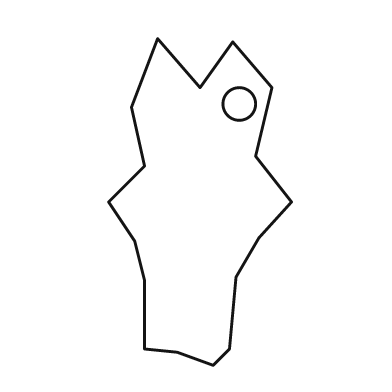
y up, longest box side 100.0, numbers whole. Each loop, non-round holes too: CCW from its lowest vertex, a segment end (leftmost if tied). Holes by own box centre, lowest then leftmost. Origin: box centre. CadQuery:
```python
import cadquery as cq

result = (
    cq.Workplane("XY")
    .moveTo(4.0, -50.0)
    .lineTo(9.0, -45.0)
    .lineTo(11.0, -23.0)
    .lineTo(18.0, -11.0)
    .lineTo(28.0, 0.0)
    .lineTo(17.0, 14.0)
    .lineTo(22.0, 35.0)
    .lineTo(10.0, 49.0)
    .lineTo(0.0, 35.0)
    .lineTo(-13.0, 50.0)
    .lineTo(-21.0, 29.0)
    .lineTo(-17.0, 11.0)
    .lineTo(-28.0, 0.0)
    .lineTo(-20.0, -12.0)
    .lineTo(-17.0, -24.0)
    .lineTo(-17.0, -45.0)
    .lineTo(-7.0, -46.0)
    .close()
    .moveTo(12.0, 30.0)
    .circle(5.0)
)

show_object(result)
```